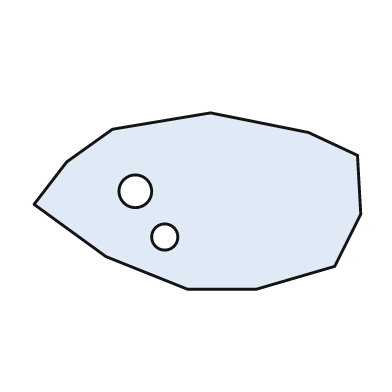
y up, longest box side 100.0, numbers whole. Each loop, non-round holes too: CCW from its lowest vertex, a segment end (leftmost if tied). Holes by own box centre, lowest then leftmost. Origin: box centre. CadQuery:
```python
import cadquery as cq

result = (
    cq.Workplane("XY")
    .moveTo(-3.0, -27.0)
    .lineTo(18.0, -27.0)
    .lineTo(42.0, -20.0)
    .lineTo(50.0, -4.0)
    .lineTo(49.0, 14.0)
    .lineTo(34.0, 21.0)
    .lineTo(4.0, 27.0)
    .lineTo(-26.0, 22.0)
    .lineTo(-40.0, 12.0)
    .lineTo(-50.0, -1.0)
    .lineTo(-28.0, -17.0)
    .close()
    .moveTo(-10.0, -11.0)
    .circle(4.0)
    .moveTo(-19.0, 3.0)
    .circle(5.0)
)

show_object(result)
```